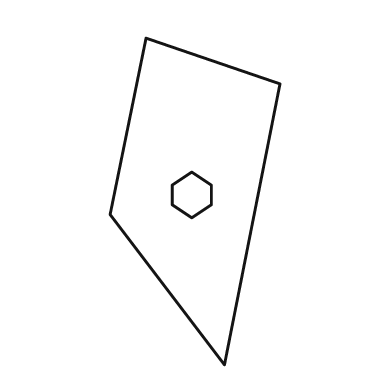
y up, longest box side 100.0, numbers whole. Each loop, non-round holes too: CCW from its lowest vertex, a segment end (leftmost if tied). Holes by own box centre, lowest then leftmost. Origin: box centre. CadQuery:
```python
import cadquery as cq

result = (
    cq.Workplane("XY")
    .moveTo(9.0, -50.0)
    .lineTo(26.0, 36.0)
    .lineTo(-15.0, 50.0)
    .lineTo(-26.0, -4.0)
    .close()
    .moveTo(-1.0, -5.0)
    .lineTo(5.0, -1.0)
    .lineTo(5.0, 5.0)
    .lineTo(-1.0, 9.0)
    .lineTo(-7.0, 5.0)
    .lineTo(-7.0, -1.0)
    .close()
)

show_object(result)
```